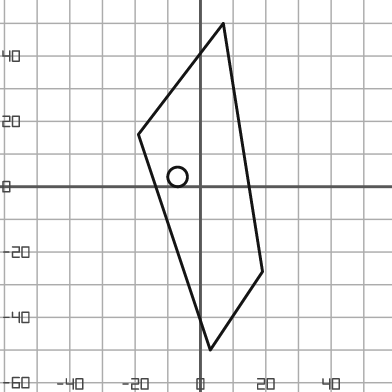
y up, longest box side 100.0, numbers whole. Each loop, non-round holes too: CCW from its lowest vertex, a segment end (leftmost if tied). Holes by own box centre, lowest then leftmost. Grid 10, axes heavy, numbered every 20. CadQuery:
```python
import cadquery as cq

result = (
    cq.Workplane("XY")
    .moveTo(3.0, -50.0)
    .lineTo(19.0, -26.0)
    .lineTo(7.0, 50.0)
    .lineTo(-19.0, 16.0)
    .close()
    .moveTo(-7.0, 3.0)
    .circle(3.0)
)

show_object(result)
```